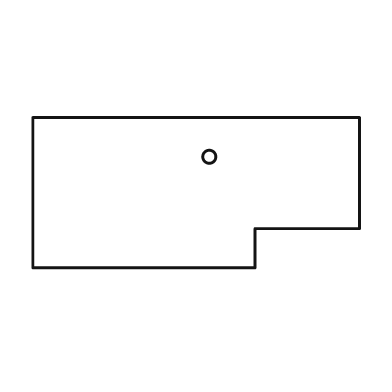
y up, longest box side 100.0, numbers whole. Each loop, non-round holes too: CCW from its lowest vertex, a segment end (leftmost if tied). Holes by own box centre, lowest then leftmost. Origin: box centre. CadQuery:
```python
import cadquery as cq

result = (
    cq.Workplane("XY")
    .moveTo(-50.0, -23.0)
    .lineTo(18.0, -23.0)
    .lineTo(18.0, -11.0)
    .lineTo(50.0, -11.0)
    .lineTo(50.0, 23.0)
    .lineTo(-50.0, 23.0)
    .close()
    .moveTo(4.0, 11.0)
    .circle(2.0)
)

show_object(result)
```